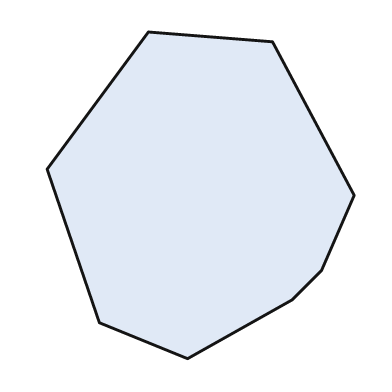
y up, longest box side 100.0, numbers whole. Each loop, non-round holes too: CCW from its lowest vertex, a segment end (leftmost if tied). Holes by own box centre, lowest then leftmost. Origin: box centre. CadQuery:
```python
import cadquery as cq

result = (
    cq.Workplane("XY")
    .moveTo(-4.0, -50.0)
    .lineTo(28.0, -32.0)
    .lineTo(37.0, -23.0)
    .lineTo(47.0, 0.0)
    .lineTo(22.0, 47.0)
    .lineTo(-16.0, 50.0)
    .lineTo(-47.0, 8.0)
    .lineTo(-31.0, -39.0)
    .close()
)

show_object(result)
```